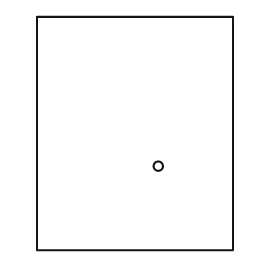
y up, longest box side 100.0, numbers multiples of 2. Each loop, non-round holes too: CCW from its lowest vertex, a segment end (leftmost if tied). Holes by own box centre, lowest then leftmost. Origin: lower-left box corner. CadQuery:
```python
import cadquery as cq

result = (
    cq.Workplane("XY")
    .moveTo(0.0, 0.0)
    .lineTo(84.0, 0.0)
    .lineTo(84.0, 100.0)
    .lineTo(0.0, 100.0)
    .close()
    .moveTo(52.0, 36.0)
    .circle(2.0)
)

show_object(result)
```